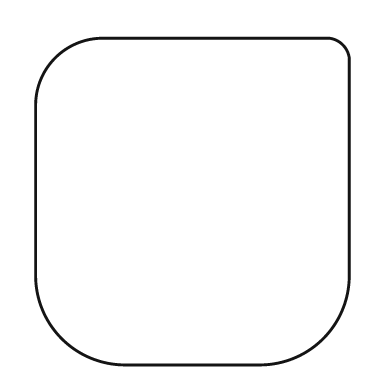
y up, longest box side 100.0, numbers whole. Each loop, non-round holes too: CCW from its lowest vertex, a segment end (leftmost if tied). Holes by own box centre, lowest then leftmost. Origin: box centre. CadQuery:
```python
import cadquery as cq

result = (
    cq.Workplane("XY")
    .moveTo(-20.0, -50.0)
    .lineTo(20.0, -50.0)
    .threePointArc((40.0, -42.0), (48.0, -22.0))
    .lineTo(48.0, 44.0)
    .threePointArc((46.0, 48.0), (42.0, 50.0))
    .lineTo(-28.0, 50.0)
    .threePointArc((-42.0, 44.0), (-48.0, 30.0))
    .lineTo(-48.0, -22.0)
    .threePointArc((-40.0, -42.0), (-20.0, -50.0))
    .close()
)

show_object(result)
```